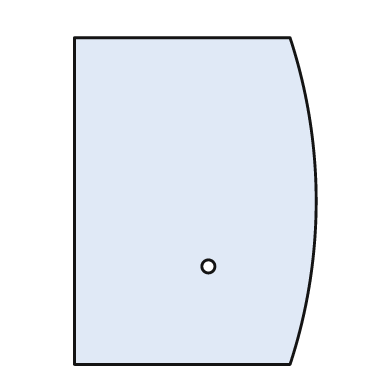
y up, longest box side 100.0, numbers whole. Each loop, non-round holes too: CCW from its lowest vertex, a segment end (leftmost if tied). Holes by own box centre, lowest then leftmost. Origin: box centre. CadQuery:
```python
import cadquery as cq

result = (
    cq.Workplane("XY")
    .moveTo(-37.0, -50.0)
    .lineTo(29.0, -50.0)
    .threePointArc((37.0, 0.0), (29.0, 50.0))
    .lineTo(-37.0, 50.0)
    .close()
    .moveTo(4.0, -20.0)
    .circle(2.0)
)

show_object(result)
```